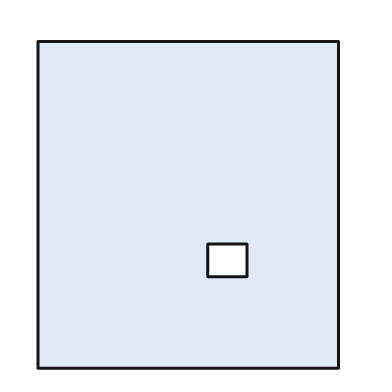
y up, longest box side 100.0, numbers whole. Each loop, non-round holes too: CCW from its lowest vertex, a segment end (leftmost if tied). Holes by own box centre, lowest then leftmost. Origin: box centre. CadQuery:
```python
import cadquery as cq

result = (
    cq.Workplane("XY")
    .moveTo(-46.0, -50.0)
    .lineTo(46.0, -50.0)
    .lineTo(46.0, 50.0)
    .lineTo(-46.0, 50.0)
    .close()
    .moveTo(6.0, -22.0)
    .lineTo(18.0, -22.0)
    .lineTo(18.0, -12.0)
    .lineTo(6.0, -12.0)
    .close()
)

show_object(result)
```